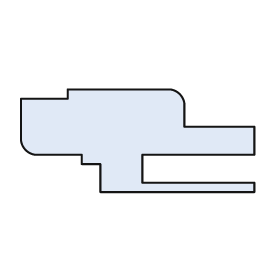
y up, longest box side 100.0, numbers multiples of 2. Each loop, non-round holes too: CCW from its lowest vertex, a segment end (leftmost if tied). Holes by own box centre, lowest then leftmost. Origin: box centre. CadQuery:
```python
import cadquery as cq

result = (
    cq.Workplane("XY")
    .moveTo(-16.0, -22.0)
    .lineTo(50.0, -22.0)
    .lineTo(50.0, -18.0)
    .lineTo(2.0, -18.0)
    .lineTo(2.0, -6.0)
    .lineTo(50.0, -6.0)
    .lineTo(50.0, 6.0)
    .lineTo(20.0, 6.0)
    .lineTo(20.0, 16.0)
    .threePointArc((18.0, 20.0), (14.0, 22.0))
    .lineTo(-30.0, 22.0)
    .lineTo(-30.0, 18.0)
    .lineTo(-50.0, 18.0)
    .lineTo(-50.0, 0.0)
    .threePointArc((-48.0, -4.0), (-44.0, -6.0))
    .lineTo(-24.0, -6.0)
    .lineTo(-24.0, -10.0)
    .lineTo(-16.0, -10.0)
    .close()
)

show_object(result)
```